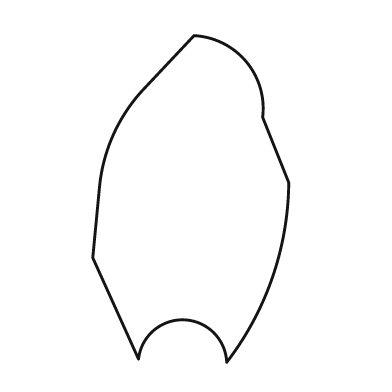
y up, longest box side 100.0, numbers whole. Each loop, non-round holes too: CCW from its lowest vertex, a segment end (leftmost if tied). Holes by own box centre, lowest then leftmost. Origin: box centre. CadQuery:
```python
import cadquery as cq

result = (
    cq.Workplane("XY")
    .moveTo(11.0, -50.0)
    .threePointArc((25.0, -24.0), (30.0, 5.0))
    .lineTo(22.0, 25.0)
    .threePointArc((17.0, 42.0), (1.0, 50.0))
    .lineTo(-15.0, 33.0)
    .threePointArc((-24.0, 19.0), (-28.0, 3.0))
    .lineTo(-30.0, -18.0)
    .lineTo(-16.0, -49.0)
    .threePointArc((-2.0, -37.0), (11.0, -50.0))
    .close()
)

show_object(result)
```